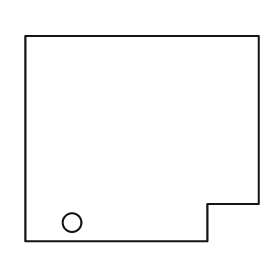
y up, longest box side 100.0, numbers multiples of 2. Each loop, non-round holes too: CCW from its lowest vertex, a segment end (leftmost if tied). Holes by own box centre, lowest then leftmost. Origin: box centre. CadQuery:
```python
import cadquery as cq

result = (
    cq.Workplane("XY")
    .moveTo(-50.0, -44.0)
    .lineTo(28.0, -44.0)
    .lineTo(28.0, -28.0)
    .lineTo(50.0, -28.0)
    .lineTo(50.0, 44.0)
    .lineTo(-50.0, 44.0)
    .close()
    .moveTo(-30.0, -36.0)
    .circle(4.0)
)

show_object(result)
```